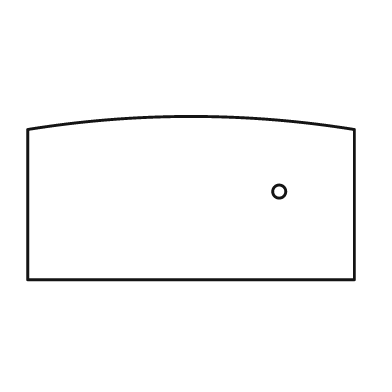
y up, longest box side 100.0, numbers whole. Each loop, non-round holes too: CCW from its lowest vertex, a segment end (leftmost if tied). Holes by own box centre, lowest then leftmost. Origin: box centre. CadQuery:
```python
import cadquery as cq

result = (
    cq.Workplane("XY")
    .moveTo(-50.0, -25.0)
    .lineTo(50.0, -25.0)
    .lineTo(50.0, 21.0)
    .threePointArc((0.0, 25.0), (-50.0, 21.0))
    .close()
    .moveTo(27.0, 2.0)
    .circle(2.0)
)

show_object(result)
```